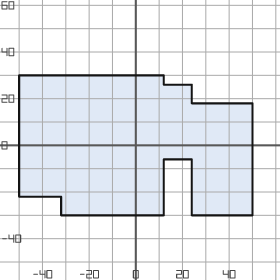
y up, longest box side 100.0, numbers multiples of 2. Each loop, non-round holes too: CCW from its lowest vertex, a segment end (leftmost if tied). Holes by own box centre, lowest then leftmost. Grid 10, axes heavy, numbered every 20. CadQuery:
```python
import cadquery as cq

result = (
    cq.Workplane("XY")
    .moveTo(-32.0, -30.0)
    .lineTo(12.0, -30.0)
    .lineTo(12.0, -6.0)
    .lineTo(24.0, -6.0)
    .lineTo(24.0, -30.0)
    .lineTo(50.0, -30.0)
    .lineTo(50.0, 18.0)
    .lineTo(24.0, 18.0)
    .lineTo(24.0, 26.0)
    .lineTo(12.0, 26.0)
    .lineTo(12.0, 30.0)
    .lineTo(-50.0, 30.0)
    .lineTo(-50.0, -22.0)
    .lineTo(-32.0, -22.0)
    .close()
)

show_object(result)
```